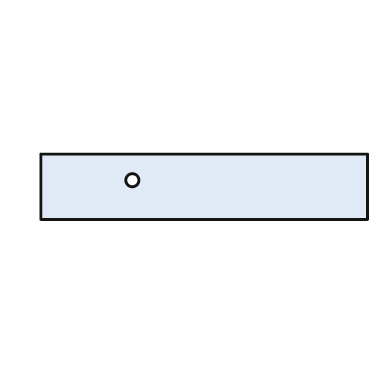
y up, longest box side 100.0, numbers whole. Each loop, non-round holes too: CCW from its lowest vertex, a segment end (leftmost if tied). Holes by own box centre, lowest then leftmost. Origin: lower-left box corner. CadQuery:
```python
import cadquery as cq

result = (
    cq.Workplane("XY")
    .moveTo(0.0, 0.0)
    .lineTo(100.0, 0.0)
    .lineTo(100.0, 20.0)
    .lineTo(0.0, 20.0)
    .close()
    .moveTo(28.0, 12.0)
    .circle(2.0)
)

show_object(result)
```